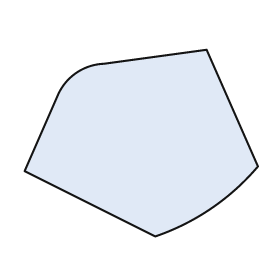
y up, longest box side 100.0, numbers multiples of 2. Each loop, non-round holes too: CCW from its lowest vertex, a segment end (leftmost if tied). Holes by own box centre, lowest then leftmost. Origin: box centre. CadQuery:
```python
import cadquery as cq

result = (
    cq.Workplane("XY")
    .moveTo(6.0, -40.0)
    .threePointArc((30.0, -28.0), (50.0, -10.0))
    .lineTo(28.0, 40.0)
    .lineTo(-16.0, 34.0)
    .threePointArc((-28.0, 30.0), (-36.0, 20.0))
    .lineTo(-50.0, -12.0)
    .close()
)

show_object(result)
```